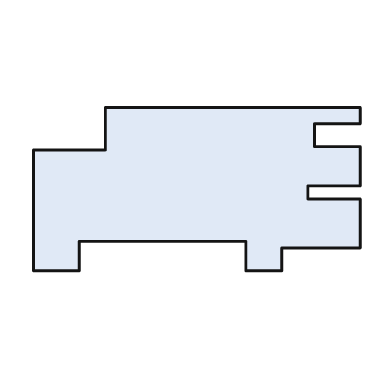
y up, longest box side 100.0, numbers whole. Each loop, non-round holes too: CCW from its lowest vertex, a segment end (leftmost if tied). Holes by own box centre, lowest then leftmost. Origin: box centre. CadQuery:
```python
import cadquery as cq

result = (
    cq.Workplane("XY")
    .moveTo(-50.0, -25.0)
    .lineTo(-36.0, -25.0)
    .lineTo(-36.0, -16.0)
    .lineTo(15.0, -16.0)
    .lineTo(15.0, -25.0)
    .lineTo(26.0, -25.0)
    .lineTo(26.0, -18.0)
    .lineTo(50.0, -18.0)
    .lineTo(50.0, -3.0)
    .lineTo(34.0, -3.0)
    .lineTo(34.0, 1.0)
    .lineTo(50.0, 1.0)
    .lineTo(50.0, 13.0)
    .lineTo(36.0, 13.0)
    .lineTo(36.0, 20.0)
    .lineTo(50.0, 20.0)
    .lineTo(50.0, 25.0)
    .lineTo(-28.0, 25.0)
    .lineTo(-28.0, 12.0)
    .lineTo(-50.0, 12.0)
    .close()
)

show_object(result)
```